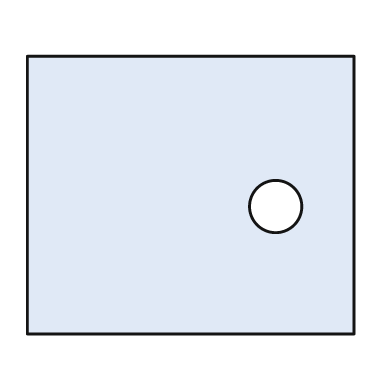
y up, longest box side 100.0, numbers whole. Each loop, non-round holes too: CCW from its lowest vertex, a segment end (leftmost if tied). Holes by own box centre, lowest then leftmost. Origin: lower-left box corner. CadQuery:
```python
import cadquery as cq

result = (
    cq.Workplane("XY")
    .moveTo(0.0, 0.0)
    .lineTo(100.0, 0.0)
    .lineTo(100.0, 85.0)
    .lineTo(0.0, 85.0)
    .close()
    .moveTo(76.0, 39.0)
    .circle(8.0)
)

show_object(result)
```